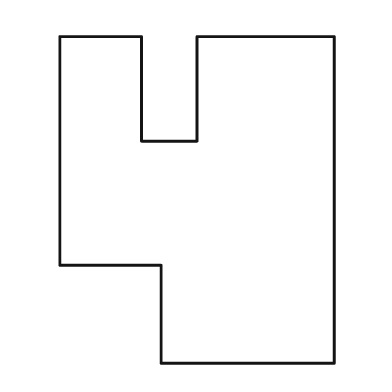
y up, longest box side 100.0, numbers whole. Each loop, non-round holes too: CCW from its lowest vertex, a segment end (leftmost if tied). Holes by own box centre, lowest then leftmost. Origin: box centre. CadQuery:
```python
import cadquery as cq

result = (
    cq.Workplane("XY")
    .moveTo(-11.0, -50.0)
    .lineTo(42.0, -50.0)
    .lineTo(42.0, 50.0)
    .lineTo(0.0, 50.0)
    .lineTo(0.0, 18.0)
    .lineTo(-17.0, 18.0)
    .lineTo(-17.0, 50.0)
    .lineTo(-42.0, 50.0)
    .lineTo(-42.0, -20.0)
    .lineTo(-11.0, -20.0)
    .close()
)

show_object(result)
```